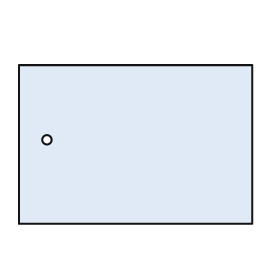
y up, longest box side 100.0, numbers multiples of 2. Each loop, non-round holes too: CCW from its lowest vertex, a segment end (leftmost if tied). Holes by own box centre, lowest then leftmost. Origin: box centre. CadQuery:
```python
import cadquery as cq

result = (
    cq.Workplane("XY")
    .moveTo(-50.0, -34.0)
    .lineTo(50.0, -34.0)
    .lineTo(50.0, 34.0)
    .lineTo(-50.0, 34.0)
    .close()
    .moveTo(-38.0, 2.0)
    .circle(2.0)
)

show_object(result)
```